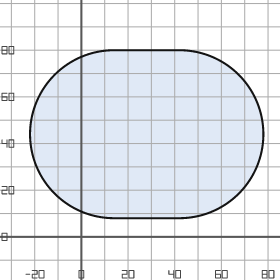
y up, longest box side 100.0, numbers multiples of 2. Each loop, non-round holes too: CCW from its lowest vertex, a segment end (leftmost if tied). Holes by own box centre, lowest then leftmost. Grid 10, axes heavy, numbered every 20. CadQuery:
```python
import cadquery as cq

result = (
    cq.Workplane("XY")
    .moveTo(14.0, 8.0)
    .lineTo(42.0, 8.0)
    .threePointArc((78.0, 44.0), (42.0, 80.0))
    .lineTo(14.0, 80.0)
    .threePointArc((-22.0, 44.0), (14.0, 8.0))
    .close()
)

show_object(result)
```